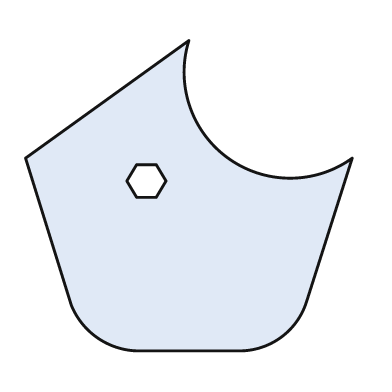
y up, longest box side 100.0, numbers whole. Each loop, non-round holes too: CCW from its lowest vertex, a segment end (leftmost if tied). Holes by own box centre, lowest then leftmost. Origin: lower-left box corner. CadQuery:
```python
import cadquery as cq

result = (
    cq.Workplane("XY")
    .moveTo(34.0, 0.0)
    .lineTo(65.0, 0.0)
    .threePointArc((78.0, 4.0), (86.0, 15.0))
    .lineTo(100.0, 59.0)
    .threePointArc((62.0, 59.0), (50.0, 95.0))
    .lineTo(0.0, 59.0)
    .lineTo(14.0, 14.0)
    .threePointArc((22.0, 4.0), (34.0, 0.0))
    .close()
    .moveTo(34.0, 47.0)
    .lineTo(40.0, 47.0)
    .lineTo(43.0, 52.0)
    .lineTo(40.0, 57.0)
    .lineTo(34.0, 57.0)
    .lineTo(31.0, 52.0)
    .close()
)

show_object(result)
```